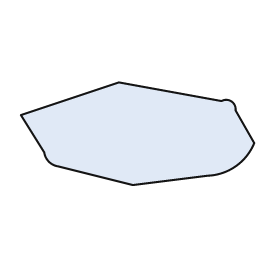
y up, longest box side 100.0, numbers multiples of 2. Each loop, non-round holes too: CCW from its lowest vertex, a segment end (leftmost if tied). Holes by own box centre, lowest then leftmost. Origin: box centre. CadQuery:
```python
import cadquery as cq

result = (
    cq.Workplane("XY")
    .moveTo(-2.0, -22.0)
    .lineTo(30.0, -18.0)
    .threePointArc((42.0, -14.0), (50.0, -4.0))
    .lineTo(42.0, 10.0)
    .threePointArc((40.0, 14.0), (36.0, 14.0))
    .lineTo(-8.0, 22.0)
    .lineTo(-50.0, 8.0)
    .lineTo(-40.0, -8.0)
    .threePointArc((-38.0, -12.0), (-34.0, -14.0))
    .close()
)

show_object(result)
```